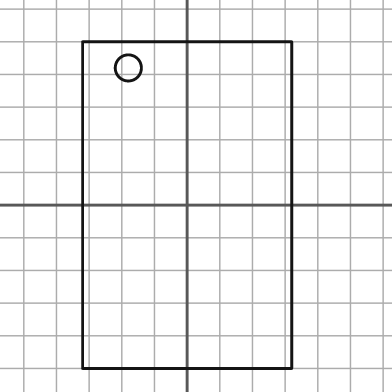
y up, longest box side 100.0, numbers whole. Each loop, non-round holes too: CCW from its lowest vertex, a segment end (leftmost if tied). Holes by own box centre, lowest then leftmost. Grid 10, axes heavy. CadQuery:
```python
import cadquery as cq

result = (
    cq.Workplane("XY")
    .moveTo(-32.0, -50.0)
    .lineTo(32.0, -50.0)
    .lineTo(32.0, 50.0)
    .lineTo(-32.0, 50.0)
    .close()
    .moveTo(-18.0, 42.0)
    .circle(4.0)
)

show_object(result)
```